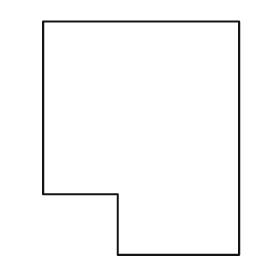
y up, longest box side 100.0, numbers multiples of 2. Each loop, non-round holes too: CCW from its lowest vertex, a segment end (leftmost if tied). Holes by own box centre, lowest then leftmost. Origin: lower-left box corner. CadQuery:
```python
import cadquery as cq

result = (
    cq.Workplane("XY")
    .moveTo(32.0, 0.0)
    .lineTo(84.0, 0.0)
    .lineTo(84.0, 100.0)
    .lineTo(0.0, 100.0)
    .lineTo(0.0, 26.0)
    .lineTo(32.0, 26.0)
    .close()
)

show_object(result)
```